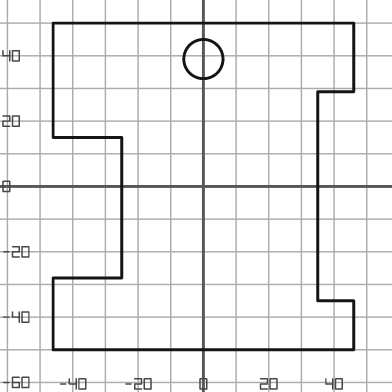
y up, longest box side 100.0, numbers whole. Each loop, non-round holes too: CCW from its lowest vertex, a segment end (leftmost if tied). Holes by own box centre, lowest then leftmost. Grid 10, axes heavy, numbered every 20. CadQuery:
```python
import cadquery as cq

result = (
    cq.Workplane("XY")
    .moveTo(-46.0, -50.0)
    .lineTo(46.0, -50.0)
    .lineTo(46.0, -35.0)
    .lineTo(35.0, -35.0)
    .lineTo(35.0, 29.0)
    .lineTo(46.0, 29.0)
    .lineTo(46.0, 50.0)
    .lineTo(-46.0, 50.0)
    .lineTo(-46.0, 15.0)
    .lineTo(-25.0, 15.0)
    .lineTo(-25.0, -28.0)
    .lineTo(-46.0, -28.0)
    .close()
    .moveTo(0.0, 39.0)
    .circle(6.0)
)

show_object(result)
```